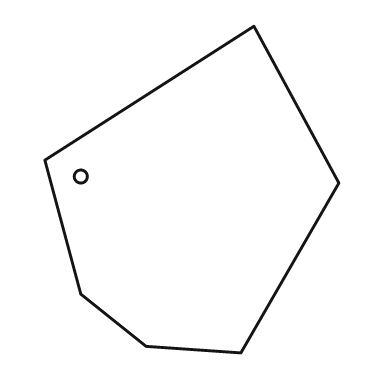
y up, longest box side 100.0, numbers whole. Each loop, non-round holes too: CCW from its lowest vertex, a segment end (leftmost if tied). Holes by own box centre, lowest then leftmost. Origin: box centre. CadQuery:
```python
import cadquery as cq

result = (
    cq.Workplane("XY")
    .moveTo(15.0, -50.0)
    .lineTo(45.0, 2.0)
    .lineTo(19.0, 50.0)
    .lineTo(-45.0, 9.0)
    .lineTo(-34.0, -32.0)
    .lineTo(-14.0, -48.0)
    .close()
    .moveTo(-34.0, 4.0)
    .circle(2.0)
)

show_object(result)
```